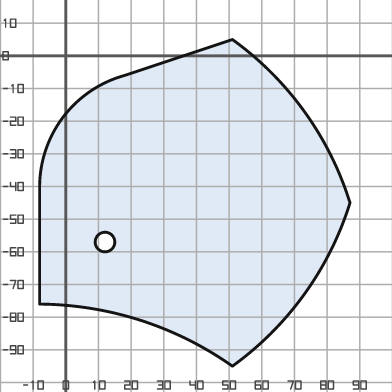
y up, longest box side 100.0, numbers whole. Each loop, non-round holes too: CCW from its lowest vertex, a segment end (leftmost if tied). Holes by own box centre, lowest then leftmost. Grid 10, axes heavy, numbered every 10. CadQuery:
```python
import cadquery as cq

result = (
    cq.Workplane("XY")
    .moveTo(51.0, -95.0)
    .threePointArc((73.0, -73.0), (87.0, -45.0))
    .threePointArc((73.0, -17.0), (51.0, 5.0))
    .lineTo(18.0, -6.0)
    .threePointArc((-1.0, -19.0), (-8.0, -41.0))
    .lineTo(-8.0, -76.0)
    .threePointArc((23.0, -81.0), (51.0, -95.0))
    .close()
    .moveTo(12.0, -57.0)
    .circle(3.0)
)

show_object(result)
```